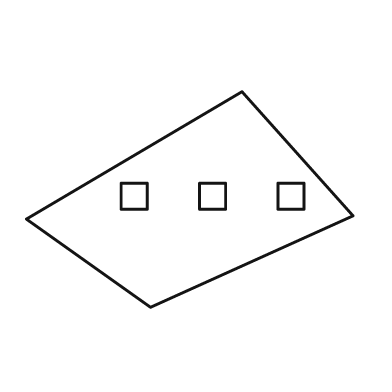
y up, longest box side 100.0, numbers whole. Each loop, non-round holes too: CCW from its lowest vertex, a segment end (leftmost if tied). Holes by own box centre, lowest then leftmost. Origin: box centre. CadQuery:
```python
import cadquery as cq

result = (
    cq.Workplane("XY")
    .moveTo(-12.0, -33.0)
    .lineTo(50.0, -5.0)
    .lineTo(16.0, 33.0)
    .lineTo(-50.0, -6.0)
    .close()
    .moveTo(-21.0, -3.0)
    .lineTo(-13.0, -3.0)
    .lineTo(-13.0, 5.0)
    .lineTo(-21.0, 5.0)
    .close()
    .moveTo(3.0, -3.0)
    .lineTo(11.0, -3.0)
    .lineTo(11.0, 5.0)
    .lineTo(3.0, 5.0)
    .close()
    .moveTo(27.0, -3.0)
    .lineTo(35.0, -3.0)
    .lineTo(35.0, 5.0)
    .lineTo(27.0, 5.0)
    .close()
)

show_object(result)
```